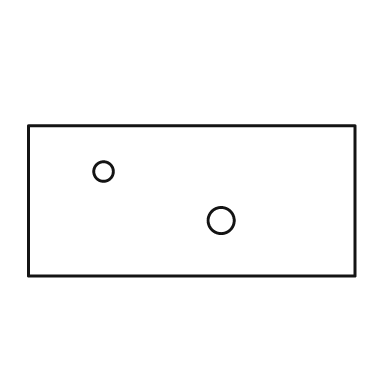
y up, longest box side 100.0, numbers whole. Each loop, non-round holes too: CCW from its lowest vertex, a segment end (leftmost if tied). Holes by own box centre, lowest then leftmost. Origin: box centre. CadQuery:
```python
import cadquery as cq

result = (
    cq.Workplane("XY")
    .moveTo(-50.0, -23.0)
    .lineTo(50.0, -23.0)
    .lineTo(50.0, 23.0)
    .lineTo(-50.0, 23.0)
    .close()
    .moveTo(9.0, -6.0)
    .circle(4.0)
    .moveTo(-27.0, 9.0)
    .circle(3.0)
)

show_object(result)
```